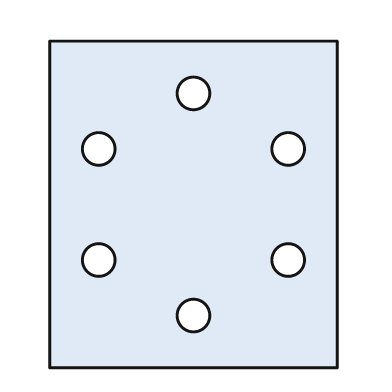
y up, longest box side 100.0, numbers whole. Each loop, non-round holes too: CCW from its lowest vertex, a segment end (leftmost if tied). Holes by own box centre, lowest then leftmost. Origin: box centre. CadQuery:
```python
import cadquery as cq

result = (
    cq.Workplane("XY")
    .moveTo(-44.0, -50.0)
    .lineTo(44.0, -50.0)
    .lineTo(44.0, 50.0)
    .lineTo(-44.0, 50.0)
    .close()
    .moveTo(0.0, -34.0)
    .circle(5.0)
    .moveTo(-29.0, -17.0)
    .circle(5.0)
    .moveTo(29.0, -17.0)
    .circle(5.0)
    .moveTo(-29.0, 17.0)
    .circle(5.0)
    .moveTo(29.0, 17.0)
    .circle(5.0)
    .moveTo(0.0, 34.0)
    .circle(5.0)
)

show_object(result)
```